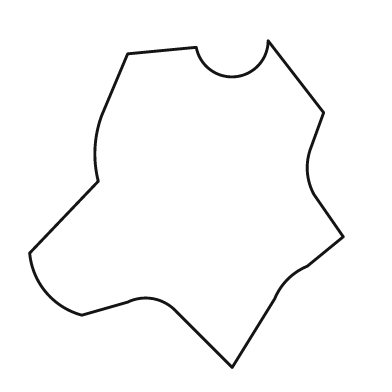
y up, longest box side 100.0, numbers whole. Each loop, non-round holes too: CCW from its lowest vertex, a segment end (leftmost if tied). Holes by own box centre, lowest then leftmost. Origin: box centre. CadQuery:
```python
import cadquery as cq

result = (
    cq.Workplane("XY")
    .moveTo(14.0, -50.0)
    .lineTo(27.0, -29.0)
    .threePointArc((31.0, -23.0), (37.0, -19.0))
    .lineTo(48.0, -10.0)
    .lineTo(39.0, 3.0)
    .threePointArc((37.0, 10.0), (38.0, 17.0))
    .lineTo(42.0, 28.0)
    .lineTo(25.0, 50.0)
    .threePointArc((15.0, 39.0), (3.0, 48.0))
    .lineTo(-18.0, 46.0)
    .lineTo(-26.0, 27.0)
    .threePointArc((-28.0, 17.0), (-27.0, 7.0))
    .lineTo(-48.0, -15.0)
    .threePointArc((-43.0, -27.0), (-32.0, -34.0))
    .lineTo(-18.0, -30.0)
    .threePointArc((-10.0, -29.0), (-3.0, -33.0))
    .close()
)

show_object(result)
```